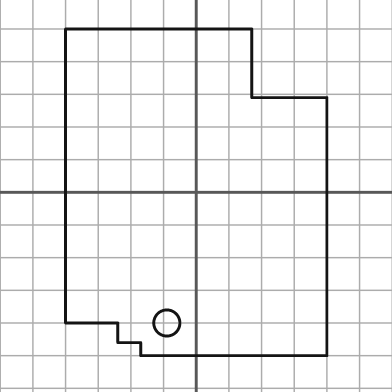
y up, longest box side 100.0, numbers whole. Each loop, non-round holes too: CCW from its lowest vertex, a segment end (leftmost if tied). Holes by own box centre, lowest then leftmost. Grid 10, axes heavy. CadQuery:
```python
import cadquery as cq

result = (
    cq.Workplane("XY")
    .moveTo(-17.0, -50.0)
    .lineTo(40.0, -50.0)
    .lineTo(40.0, 29.0)
    .lineTo(17.0, 29.0)
    .lineTo(17.0, 50.0)
    .lineTo(-40.0, 50.0)
    .lineTo(-40.0, -40.0)
    .lineTo(-24.0, -40.0)
    .lineTo(-24.0, -46.0)
    .lineTo(-17.0, -46.0)
    .close()
    .moveTo(-9.0, -40.0)
    .circle(4.0)
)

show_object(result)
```